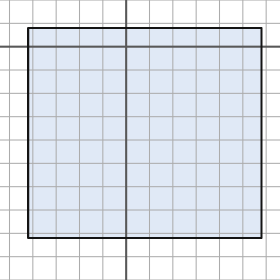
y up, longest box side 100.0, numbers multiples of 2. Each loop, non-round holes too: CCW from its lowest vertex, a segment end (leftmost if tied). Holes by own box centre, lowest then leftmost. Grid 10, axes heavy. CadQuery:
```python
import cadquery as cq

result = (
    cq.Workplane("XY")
    .moveTo(-42.0, -82.0)
    .lineTo(58.0, -82.0)
    .lineTo(58.0, 8.0)
    .lineTo(-42.0, 8.0)
    .close()
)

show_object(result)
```